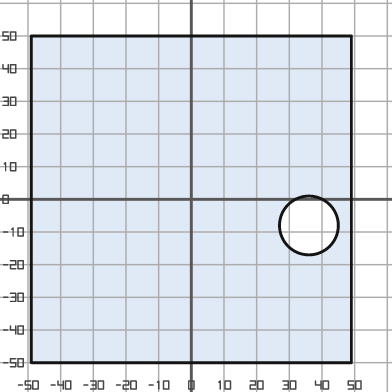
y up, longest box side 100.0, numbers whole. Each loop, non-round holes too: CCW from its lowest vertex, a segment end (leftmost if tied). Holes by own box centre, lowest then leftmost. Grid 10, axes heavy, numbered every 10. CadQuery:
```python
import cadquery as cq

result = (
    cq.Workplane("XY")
    .moveTo(-49.0, -50.0)
    .lineTo(49.0, -50.0)
    .lineTo(49.0, 50.0)
    .lineTo(-49.0, 50.0)
    .close()
    .moveTo(36.0, -8.0)
    .circle(9.0)
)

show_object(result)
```